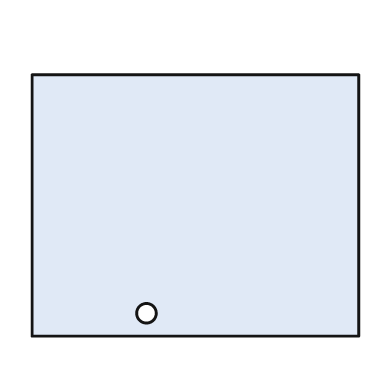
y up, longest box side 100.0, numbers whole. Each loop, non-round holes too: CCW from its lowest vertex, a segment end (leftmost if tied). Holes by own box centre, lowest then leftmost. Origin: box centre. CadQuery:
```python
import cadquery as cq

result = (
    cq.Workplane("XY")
    .moveTo(-50.0, -40.0)
    .lineTo(50.0, -40.0)
    .lineTo(50.0, 40.0)
    .lineTo(-50.0, 40.0)
    .close()
    .moveTo(-15.0, -33.0)
    .circle(3.0)
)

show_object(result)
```